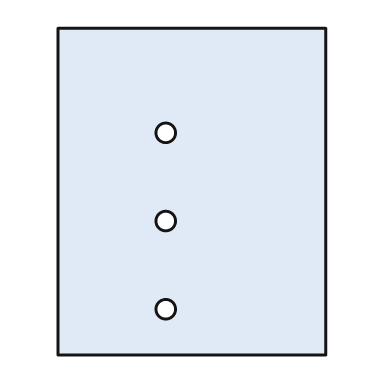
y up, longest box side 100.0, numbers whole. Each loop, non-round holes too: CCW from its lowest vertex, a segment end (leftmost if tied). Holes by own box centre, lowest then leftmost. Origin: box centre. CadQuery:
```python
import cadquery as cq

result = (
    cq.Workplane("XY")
    .moveTo(-41.0, -50.0)
    .lineTo(41.0, -50.0)
    .lineTo(41.0, 50.0)
    .lineTo(-41.0, 50.0)
    .close()
    .moveTo(-8.0, -36.0)
    .circle(3.0)
    .moveTo(-8.0, -9.0)
    .circle(3.0)
    .moveTo(-8.0, 18.0)
    .circle(3.0)
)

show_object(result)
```